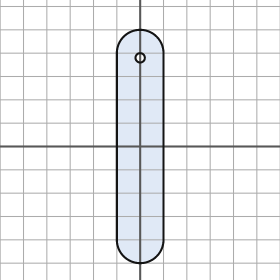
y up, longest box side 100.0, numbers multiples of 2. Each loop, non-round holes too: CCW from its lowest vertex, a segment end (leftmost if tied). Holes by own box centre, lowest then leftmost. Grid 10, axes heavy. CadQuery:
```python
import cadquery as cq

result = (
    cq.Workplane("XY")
    .moveTo(-10.0, -40.0)
    .threePointArc((0.0, -50.0), (10.0, -40.0))
    .lineTo(10.0, 40.0)
    .threePointArc((0.0, 50.0), (-10.0, 40.0))
    .close()
    .moveTo(0.0, 38.0)
    .circle(2.0)
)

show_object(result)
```